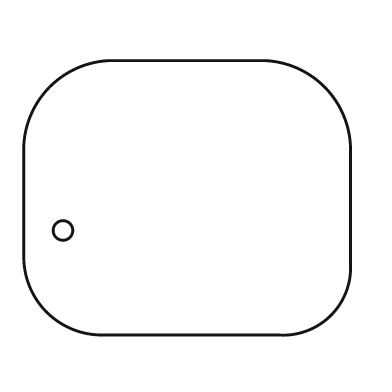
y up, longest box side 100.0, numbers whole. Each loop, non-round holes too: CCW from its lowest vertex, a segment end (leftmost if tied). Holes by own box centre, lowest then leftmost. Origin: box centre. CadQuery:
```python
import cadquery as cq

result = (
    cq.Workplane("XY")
    .moveTo(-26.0, -42.0)
    .lineTo(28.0, -42.0)
    .threePointArc((44.0, -36.0), (50.0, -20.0))
    .lineTo(50.0, 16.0)
    .threePointArc((42.0, 34.0), (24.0, 42.0))
    .lineTo(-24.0, 42.0)
    .threePointArc((-42.0, 34.0), (-50.0, 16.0))
    .lineTo(-50.0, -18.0)
    .threePointArc((-43.0, -35.0), (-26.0, -42.0))
    .close()
    .moveTo(-38.0, -10.0)
    .circle(3.0)
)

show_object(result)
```